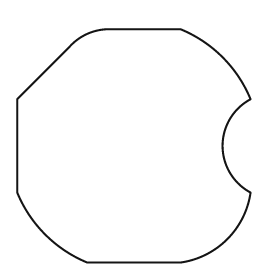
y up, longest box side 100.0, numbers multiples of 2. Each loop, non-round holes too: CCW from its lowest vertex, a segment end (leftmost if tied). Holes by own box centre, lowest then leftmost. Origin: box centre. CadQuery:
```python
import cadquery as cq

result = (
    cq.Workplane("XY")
    .moveTo(-20.0, -50.0)
    .lineTo(20.0, -50.0)
    .threePointArc((40.0, -40.0), (50.0, -20.0))
    .threePointArc((38.0, 0.0), (50.0, 20.0))
    .threePointArc((38.0, 38.0), (20.0, 50.0))
    .lineTo(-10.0, 50.0)
    .threePointArc((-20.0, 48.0), (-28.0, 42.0))
    .lineTo(-50.0, 20.0)
    .lineTo(-50.0, -20.0)
    .threePointArc((-38.0, -38.0), (-20.0, -50.0))
    .close()
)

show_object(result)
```